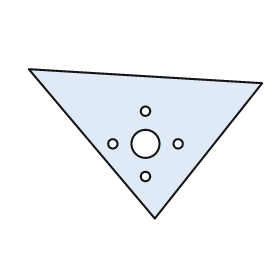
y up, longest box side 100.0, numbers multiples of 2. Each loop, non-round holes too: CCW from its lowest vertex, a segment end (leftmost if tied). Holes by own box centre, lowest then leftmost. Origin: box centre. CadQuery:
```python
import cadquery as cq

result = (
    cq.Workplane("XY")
    .moveTo(4.0, -32.0)
    .lineTo(50.0, 26.0)
    .lineTo(-50.0, 32.0)
    .close()
    .moveTo(0.0, -14.0)
    .circle(2.0)
    .moveTo(-14.0, 0.0)
    .circle(2.0)
    .moveTo(0.0, 0.0)
    .circle(6.0)
    .moveTo(14.0, 0.0)
    .circle(2.0)
    .moveTo(0.0, 14.0)
    .circle(2.0)
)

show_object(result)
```